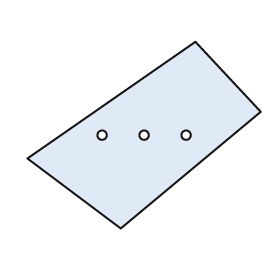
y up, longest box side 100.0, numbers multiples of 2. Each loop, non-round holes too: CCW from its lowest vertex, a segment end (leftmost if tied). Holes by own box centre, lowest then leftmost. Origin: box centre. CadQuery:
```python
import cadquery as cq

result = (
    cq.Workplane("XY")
    .moveTo(-10.0, -40.0)
    .lineTo(50.0, 10.0)
    .lineTo(22.0, 40.0)
    .lineTo(-50.0, -10.0)
    .close()
    .moveTo(-18.0, 0.0)
    .circle(2.0)
    .moveTo(0.0, 0.0)
    .circle(2.0)
    .moveTo(18.0, 0.0)
    .circle(2.0)
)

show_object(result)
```